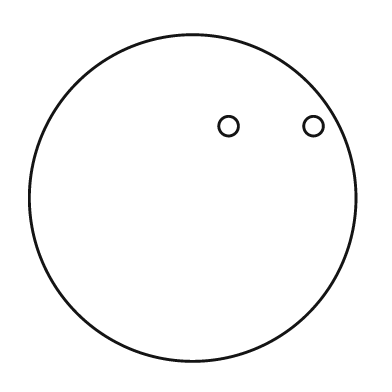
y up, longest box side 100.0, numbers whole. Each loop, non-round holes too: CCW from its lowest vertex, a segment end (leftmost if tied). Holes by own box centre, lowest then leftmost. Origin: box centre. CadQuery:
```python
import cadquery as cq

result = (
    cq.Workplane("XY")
    .moveTo(0.0, 0.0)
    .circle(50.0)
    .moveTo(11.0, 22.0)
    .circle(3.0)
    .moveTo(37.0, 22.0)
    .circle(3.0)
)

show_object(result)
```